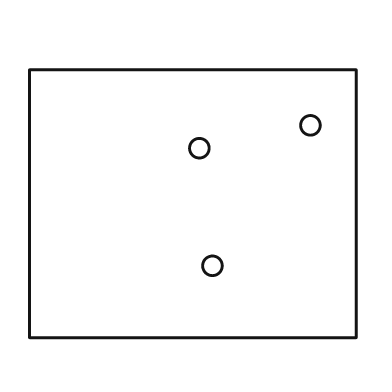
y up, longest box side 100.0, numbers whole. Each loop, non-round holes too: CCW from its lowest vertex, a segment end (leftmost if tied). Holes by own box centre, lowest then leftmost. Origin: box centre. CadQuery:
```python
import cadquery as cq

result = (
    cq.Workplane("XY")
    .moveTo(-50.0, -41.0)
    .lineTo(50.0, -41.0)
    .lineTo(50.0, 41.0)
    .lineTo(-50.0, 41.0)
    .close()
    .moveTo(6.0, -19.0)
    .circle(3.0)
    .moveTo(2.0, 17.0)
    .circle(3.0)
    .moveTo(36.0, 24.0)
    .circle(3.0)
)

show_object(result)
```